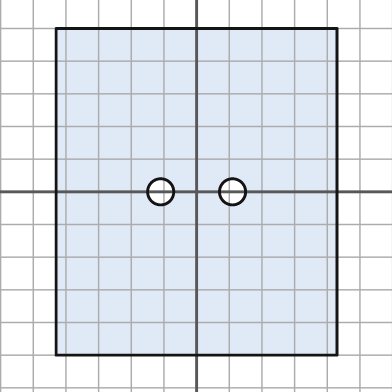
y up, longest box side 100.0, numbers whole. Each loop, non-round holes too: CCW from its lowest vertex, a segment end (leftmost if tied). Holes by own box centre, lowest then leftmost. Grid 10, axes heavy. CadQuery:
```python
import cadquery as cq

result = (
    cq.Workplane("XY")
    .moveTo(-43.0, -50.0)
    .lineTo(43.0, -50.0)
    .lineTo(43.0, 50.0)
    .lineTo(-43.0, 50.0)
    .close()
    .moveTo(-11.0, 0.0)
    .circle(4.0)
    .moveTo(11.0, 0.0)
    .circle(4.0)
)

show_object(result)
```